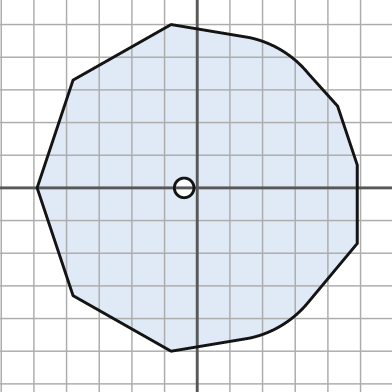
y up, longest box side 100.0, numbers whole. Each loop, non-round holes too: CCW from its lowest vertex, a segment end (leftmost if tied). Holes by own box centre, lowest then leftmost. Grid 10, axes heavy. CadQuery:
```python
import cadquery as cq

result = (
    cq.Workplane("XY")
    .moveTo(-8.0, -50.0)
    .lineTo(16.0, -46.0)
    .threePointArc((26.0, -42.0), (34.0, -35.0))
    .lineTo(49.0, -17.0)
    .lineTo(49.0, 7.0)
    .lineTo(43.0, 25.0)
    .lineTo(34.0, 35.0)
    .threePointArc((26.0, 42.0), (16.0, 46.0))
    .lineTo(-8.0, 50.0)
    .lineTo(-38.0, 33.0)
    .lineTo(-49.0, 0.0)
    .lineTo(-38.0, -33.0)
    .close()
    .moveTo(-4.0, 0.0)
    .circle(3.0)
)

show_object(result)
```